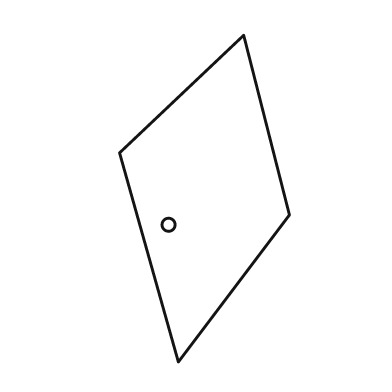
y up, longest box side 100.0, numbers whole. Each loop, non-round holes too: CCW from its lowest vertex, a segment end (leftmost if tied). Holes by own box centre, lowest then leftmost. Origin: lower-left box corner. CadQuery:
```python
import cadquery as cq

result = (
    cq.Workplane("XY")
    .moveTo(18.0, 0.0)
    .lineTo(52.0, 45.0)
    .lineTo(38.0, 100.0)
    .lineTo(0.0, 64.0)
    .close()
    .moveTo(15.0, 42.0)
    .circle(2.0)
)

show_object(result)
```